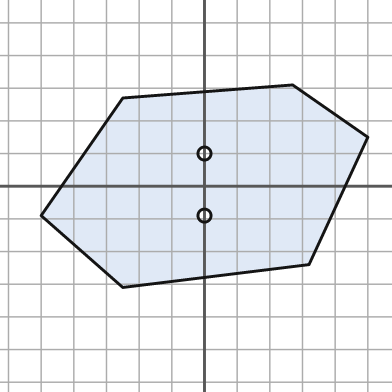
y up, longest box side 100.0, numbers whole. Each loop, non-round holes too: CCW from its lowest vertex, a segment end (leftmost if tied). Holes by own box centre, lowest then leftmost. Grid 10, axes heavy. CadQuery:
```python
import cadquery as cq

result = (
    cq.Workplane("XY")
    .moveTo(-25.0, -31.0)
    .lineTo(32.0, -24.0)
    .lineTo(50.0, 15.0)
    .lineTo(27.0, 31.0)
    .lineTo(-25.0, 27.0)
    .lineTo(-50.0, -9.0)
    .close()
    .moveTo(0.0, -9.0)
    .circle(2.0)
    .moveTo(0.0, 10.0)
    .circle(2.0)
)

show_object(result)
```